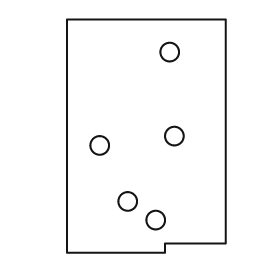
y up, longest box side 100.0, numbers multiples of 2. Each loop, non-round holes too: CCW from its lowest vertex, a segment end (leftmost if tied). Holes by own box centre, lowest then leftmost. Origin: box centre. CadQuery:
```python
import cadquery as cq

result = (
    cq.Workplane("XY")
    .moveTo(-34.0, -50.0)
    .lineTo(8.0, -50.0)
    .lineTo(8.0, -46.0)
    .lineTo(34.0, -46.0)
    .lineTo(34.0, 50.0)
    .lineTo(-34.0, 50.0)
    .close()
    .moveTo(4.0, -36.0)
    .circle(4.0)
    .moveTo(-8.0, -28.0)
    .circle(4.0)
    .moveTo(-20.0, -4.0)
    .circle(4.0)
    .moveTo(12.0, 0.0)
    .circle(4.0)
    .moveTo(10.0, 36.0)
    .circle(4.0)
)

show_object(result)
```